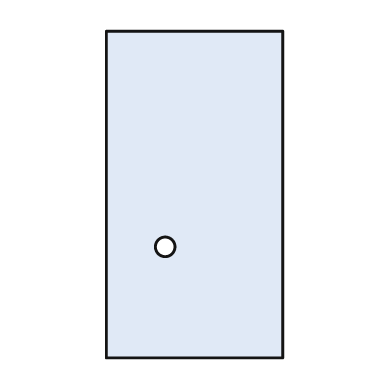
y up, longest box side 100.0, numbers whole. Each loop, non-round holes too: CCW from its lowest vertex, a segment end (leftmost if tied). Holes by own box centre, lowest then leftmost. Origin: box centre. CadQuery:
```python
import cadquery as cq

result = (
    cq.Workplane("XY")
    .moveTo(-27.0, -50.0)
    .lineTo(27.0, -50.0)
    .lineTo(27.0, 50.0)
    .lineTo(-27.0, 50.0)
    .close()
    .moveTo(-9.0, -16.0)
    .circle(3.0)
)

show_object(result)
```